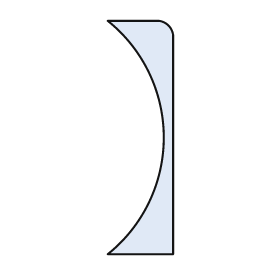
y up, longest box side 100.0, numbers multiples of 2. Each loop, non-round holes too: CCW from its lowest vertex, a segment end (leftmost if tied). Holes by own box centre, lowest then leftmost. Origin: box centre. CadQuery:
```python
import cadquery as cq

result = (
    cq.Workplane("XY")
    .moveTo(-14.0, -50.0)
    .lineTo(14.0, -50.0)
    .lineTo(14.0, 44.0)
    .threePointArc((12.0, 48.0), (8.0, 50.0))
    .lineTo(-14.0, 50.0)
    .threePointArc((10.0, 0.0), (-14.0, -50.0))
    .close()
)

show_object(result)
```